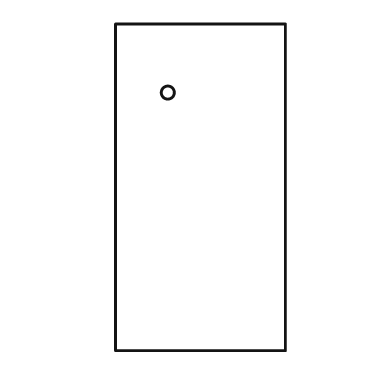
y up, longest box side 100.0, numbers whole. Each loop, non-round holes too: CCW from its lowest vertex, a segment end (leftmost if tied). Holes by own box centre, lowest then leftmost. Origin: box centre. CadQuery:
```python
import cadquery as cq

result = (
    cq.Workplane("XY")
    .moveTo(-26.0, -50.0)
    .lineTo(26.0, -50.0)
    .lineTo(26.0, 50.0)
    .lineTo(-26.0, 50.0)
    .close()
    .moveTo(-10.0, 29.0)
    .circle(2.0)
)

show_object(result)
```